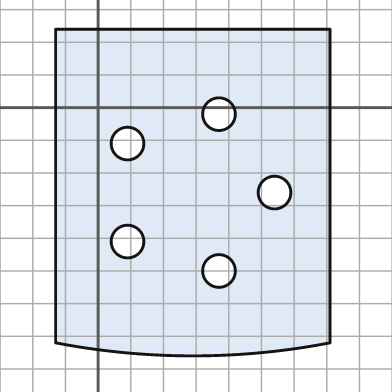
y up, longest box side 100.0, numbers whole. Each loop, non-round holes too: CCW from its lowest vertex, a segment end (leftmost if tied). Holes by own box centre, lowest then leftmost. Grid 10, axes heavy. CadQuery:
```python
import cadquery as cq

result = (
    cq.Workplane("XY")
    .moveTo(-13.0, -72.0)
    .threePointArc((29.0, -76.0), (71.0, -72.0))
    .lineTo(71.0, 24.0)
    .lineTo(-13.0, 24.0)
    .close()
    .moveTo(37.0, -50.0)
    .circle(5.0)
    .moveTo(9.0, -41.0)
    .circle(5.0)
    .moveTo(54.0, -26.0)
    .circle(5.0)
    .moveTo(9.0, -11.0)
    .circle(5.0)
    .moveTo(37.0, -2.0)
    .circle(5.0)
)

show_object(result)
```